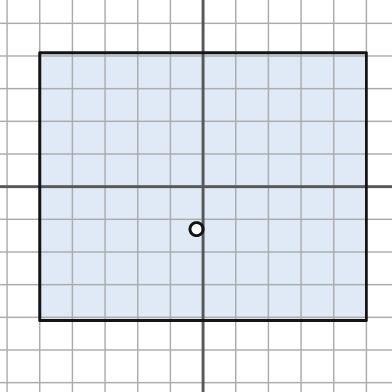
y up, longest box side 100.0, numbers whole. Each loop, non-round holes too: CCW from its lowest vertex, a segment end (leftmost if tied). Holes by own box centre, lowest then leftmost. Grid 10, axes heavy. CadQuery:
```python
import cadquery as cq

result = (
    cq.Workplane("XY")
    .moveTo(-50.0, -41.0)
    .lineTo(50.0, -41.0)
    .lineTo(50.0, 41.0)
    .lineTo(-50.0, 41.0)
    .close()
    .moveTo(-2.0, -13.0)
    .circle(2.0)
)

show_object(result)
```